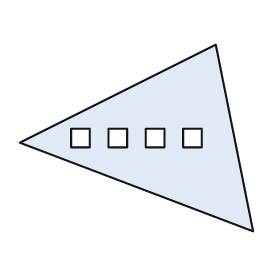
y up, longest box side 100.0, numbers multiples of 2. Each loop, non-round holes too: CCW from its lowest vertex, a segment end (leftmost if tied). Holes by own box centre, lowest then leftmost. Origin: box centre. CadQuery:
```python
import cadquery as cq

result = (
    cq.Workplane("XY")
    .moveTo(50.0, -40.0)
    .lineTo(34.0, 40.0)
    .lineTo(-50.0, -2.0)
    .close()
    .moveTo(-28.0, -4.0)
    .lineTo(-20.0, -4.0)
    .lineTo(-20.0, 4.0)
    .lineTo(-28.0, 4.0)
    .close()
    .moveTo(-12.0, -4.0)
    .lineTo(-4.0, -4.0)
    .lineTo(-4.0, 4.0)
    .lineTo(-12.0, 4.0)
    .close()
    .moveTo(4.0, -4.0)
    .lineTo(12.0, -4.0)
    .lineTo(12.0, 4.0)
    .lineTo(4.0, 4.0)
    .close()
    .moveTo(20.0, -4.0)
    .lineTo(28.0, -4.0)
    .lineTo(28.0, 4.0)
    .lineTo(20.0, 4.0)
    .close()
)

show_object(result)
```